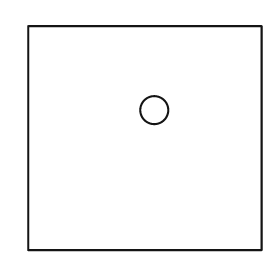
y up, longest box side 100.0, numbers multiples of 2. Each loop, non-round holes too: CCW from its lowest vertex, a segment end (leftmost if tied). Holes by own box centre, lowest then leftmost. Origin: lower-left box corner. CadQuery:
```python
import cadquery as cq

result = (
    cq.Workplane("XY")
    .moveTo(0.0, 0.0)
    .lineTo(100.0, 0.0)
    .lineTo(100.0, 96.0)
    .lineTo(0.0, 96.0)
    .close()
    .moveTo(54.0, 60.0)
    .circle(6.0)
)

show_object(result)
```